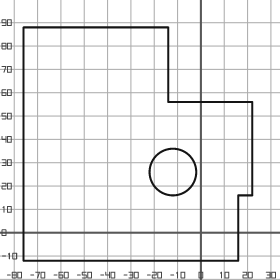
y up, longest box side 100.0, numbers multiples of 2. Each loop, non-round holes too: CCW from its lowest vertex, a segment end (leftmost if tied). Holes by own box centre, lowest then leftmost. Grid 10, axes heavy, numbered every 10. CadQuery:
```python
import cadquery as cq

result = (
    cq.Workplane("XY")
    .moveTo(-76.0, -12.0)
    .lineTo(16.0, -12.0)
    .lineTo(16.0, 16.0)
    .lineTo(22.0, 16.0)
    .lineTo(22.0, 56.0)
    .lineTo(-14.0, 56.0)
    .lineTo(-14.0, 88.0)
    .lineTo(-76.0, 88.0)
    .close()
    .moveTo(-12.0, 26.0)
    .circle(10.0)
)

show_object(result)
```